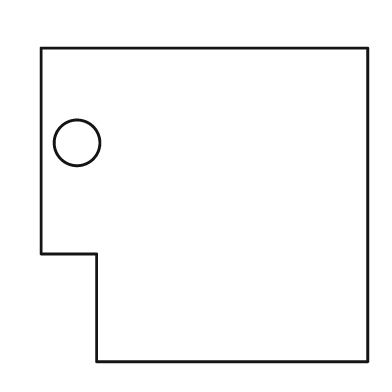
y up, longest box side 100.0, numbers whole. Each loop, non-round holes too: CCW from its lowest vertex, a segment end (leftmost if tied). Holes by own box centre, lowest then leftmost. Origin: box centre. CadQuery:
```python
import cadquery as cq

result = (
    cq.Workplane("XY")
    .moveTo(-33.0, -48.0)
    .lineTo(50.0, -48.0)
    .lineTo(50.0, 48.0)
    .lineTo(-50.0, 48.0)
    .lineTo(-50.0, -15.0)
    .lineTo(-33.0, -15.0)
    .close()
    .moveTo(-39.0, 19.0)
    .circle(7.0)
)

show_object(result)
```